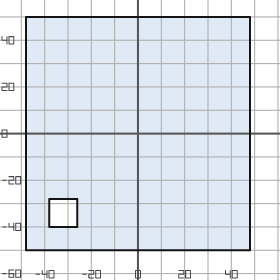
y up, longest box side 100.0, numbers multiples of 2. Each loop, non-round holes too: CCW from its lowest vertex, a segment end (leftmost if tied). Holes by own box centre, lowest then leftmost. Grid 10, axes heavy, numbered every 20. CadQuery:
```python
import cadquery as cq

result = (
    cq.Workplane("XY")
    .moveTo(-48.0, -50.0)
    .lineTo(48.0, -50.0)
    .lineTo(48.0, 50.0)
    .lineTo(-48.0, 50.0)
    .close()
    .moveTo(-38.0, -40.0)
    .lineTo(-26.0, -40.0)
    .lineTo(-26.0, -28.0)
    .lineTo(-38.0, -28.0)
    .close()
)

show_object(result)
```